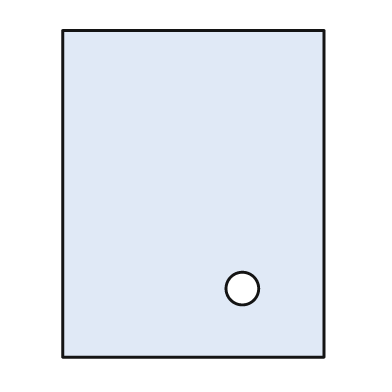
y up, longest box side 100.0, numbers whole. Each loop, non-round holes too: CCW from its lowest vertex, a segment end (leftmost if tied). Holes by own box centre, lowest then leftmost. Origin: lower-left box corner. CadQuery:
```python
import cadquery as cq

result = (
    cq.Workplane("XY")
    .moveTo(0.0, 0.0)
    .lineTo(80.0, 0.0)
    .lineTo(80.0, 100.0)
    .lineTo(0.0, 100.0)
    .close()
    .moveTo(55.0, 21.0)
    .circle(5.0)
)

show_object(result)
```